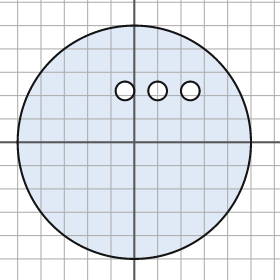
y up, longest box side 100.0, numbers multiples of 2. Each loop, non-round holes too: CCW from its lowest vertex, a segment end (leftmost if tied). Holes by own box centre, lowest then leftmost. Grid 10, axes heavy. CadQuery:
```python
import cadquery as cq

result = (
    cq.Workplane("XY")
    .moveTo(0.0, 0.0)
    .circle(50.0)
    .moveTo(-4.0, 22.0)
    .circle(4.0)
    .moveTo(10.0, 22.0)
    .circle(4.0)
    .moveTo(24.0, 22.0)
    .circle(4.0)
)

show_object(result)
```